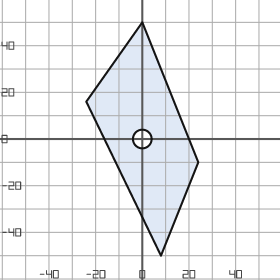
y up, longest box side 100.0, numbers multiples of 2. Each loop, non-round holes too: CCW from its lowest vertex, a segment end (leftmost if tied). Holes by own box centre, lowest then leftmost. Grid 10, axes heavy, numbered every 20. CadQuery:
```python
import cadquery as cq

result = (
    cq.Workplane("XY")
    .moveTo(8.0, -50.0)
    .lineTo(24.0, -10.0)
    .lineTo(0.0, 50.0)
    .lineTo(-24.0, 16.0)
    .close()
    .moveTo(0.0, 0.0)
    .circle(4.0)
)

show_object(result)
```